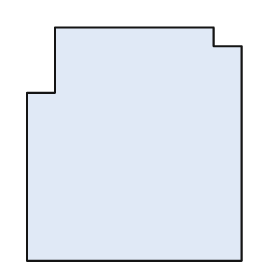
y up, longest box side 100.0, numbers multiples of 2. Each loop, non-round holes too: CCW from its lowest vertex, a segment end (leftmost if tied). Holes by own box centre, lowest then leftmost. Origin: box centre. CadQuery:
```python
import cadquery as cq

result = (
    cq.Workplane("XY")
    .moveTo(-46.0, -50.0)
    .lineTo(46.0, -50.0)
    .lineTo(46.0, 42.0)
    .lineTo(34.0, 42.0)
    .lineTo(34.0, 50.0)
    .lineTo(-34.0, 50.0)
    .lineTo(-34.0, 22.0)
    .lineTo(-46.0, 22.0)
    .close()
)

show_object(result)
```